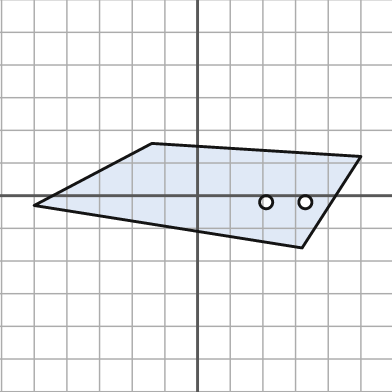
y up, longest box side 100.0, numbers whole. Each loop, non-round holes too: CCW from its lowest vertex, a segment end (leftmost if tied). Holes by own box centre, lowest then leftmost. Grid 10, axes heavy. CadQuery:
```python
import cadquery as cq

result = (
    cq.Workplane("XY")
    .moveTo(32.0, -16.0)
    .lineTo(50.0, 12.0)
    .lineTo(-14.0, 16.0)
    .lineTo(-50.0, -3.0)
    .close()
    .moveTo(21.0, -2.0)
    .circle(2.0)
    .moveTo(33.0, -2.0)
    .circle(2.0)
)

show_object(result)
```